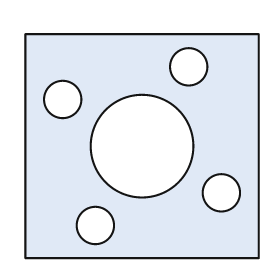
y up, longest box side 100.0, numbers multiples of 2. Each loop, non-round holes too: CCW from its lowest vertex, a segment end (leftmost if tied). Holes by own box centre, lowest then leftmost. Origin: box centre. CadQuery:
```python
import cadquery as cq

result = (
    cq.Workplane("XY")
    .moveTo(-50.0, -48.0)
    .lineTo(50.0, -48.0)
    .lineTo(50.0, 48.0)
    .lineTo(-50.0, 48.0)
    .close()
    .moveTo(-20.0, -34.0)
    .circle(8.0)
    .moveTo(34.0, -20.0)
    .circle(8.0)
    .moveTo(0.0, 0.0)
    .circle(22.0)
    .moveTo(-34.0, 20.0)
    .circle(8.0)
    .moveTo(20.0, 34.0)
    .circle(8.0)
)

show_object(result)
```